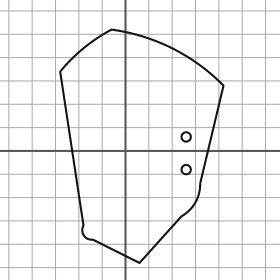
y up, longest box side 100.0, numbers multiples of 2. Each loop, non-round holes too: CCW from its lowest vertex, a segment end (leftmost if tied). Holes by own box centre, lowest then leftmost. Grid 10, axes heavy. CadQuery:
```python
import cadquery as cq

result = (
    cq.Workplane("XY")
    .moveTo(6.0, -48.0)
    .lineTo(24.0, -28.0)
    .threePointArc((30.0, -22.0), (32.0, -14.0))
    .lineTo(42.0, 28.0)
    .threePointArc((20.0, 44.0), (-6.0, 52.0))
    .threePointArc((-18.0, 44.0), (-28.0, 34.0))
    .lineTo(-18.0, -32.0)
    .threePointArc((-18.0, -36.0), (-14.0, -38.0))
    .close()
    .moveTo(26.0, -8.0)
    .circle(2.0)
    .moveTo(26.0, 6.0)
    .circle(2.0)
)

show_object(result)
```